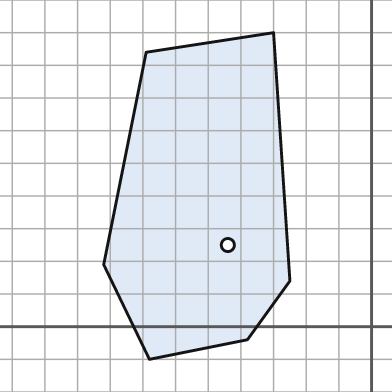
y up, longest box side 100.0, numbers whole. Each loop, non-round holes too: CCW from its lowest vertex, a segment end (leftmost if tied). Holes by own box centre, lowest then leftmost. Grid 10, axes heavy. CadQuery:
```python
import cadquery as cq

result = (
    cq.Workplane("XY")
    .moveTo(-68.0, -10.0)
    .lineTo(-38.0, -4.0)
    .lineTo(-25.0, 14.0)
    .lineTo(-30.0, 90.0)
    .lineTo(-69.0, 84.0)
    .lineTo(-82.0, 19.0)
    .close()
    .moveTo(-44.0, 25.0)
    .circle(2.0)
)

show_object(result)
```